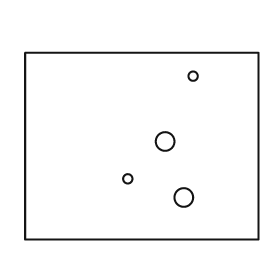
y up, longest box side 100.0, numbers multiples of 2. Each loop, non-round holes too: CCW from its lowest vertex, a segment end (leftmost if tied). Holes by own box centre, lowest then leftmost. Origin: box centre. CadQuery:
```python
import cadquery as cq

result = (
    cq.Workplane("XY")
    .moveTo(-50.0, -40.0)
    .lineTo(50.0, -40.0)
    .lineTo(50.0, 40.0)
    .lineTo(-50.0, 40.0)
    .close()
    .moveTo(18.0, -22.0)
    .circle(4.0)
    .moveTo(-6.0, -14.0)
    .circle(2.0)
    .moveTo(10.0, 2.0)
    .circle(4.0)
    .moveTo(22.0, 30.0)
    .circle(2.0)
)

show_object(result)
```